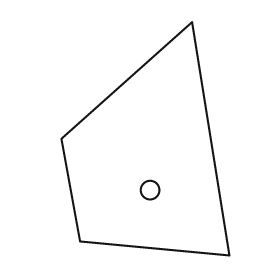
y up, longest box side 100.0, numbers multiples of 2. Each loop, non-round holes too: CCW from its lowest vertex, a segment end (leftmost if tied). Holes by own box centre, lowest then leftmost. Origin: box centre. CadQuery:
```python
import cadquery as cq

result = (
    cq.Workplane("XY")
    .moveTo(36.0, -50.0)
    .lineTo(20.0, 50.0)
    .lineTo(-36.0, 0.0)
    .lineTo(-28.0, -44.0)
    .close()
    .moveTo(2.0, -22.0)
    .circle(4.0)
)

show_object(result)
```